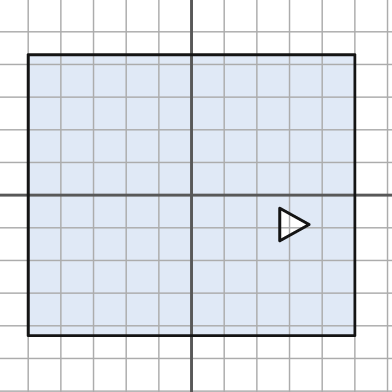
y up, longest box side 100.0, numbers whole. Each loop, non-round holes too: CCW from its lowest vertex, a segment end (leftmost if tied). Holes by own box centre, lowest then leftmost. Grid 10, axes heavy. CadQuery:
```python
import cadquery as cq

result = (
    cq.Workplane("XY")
    .moveTo(-50.0, -43.0)
    .lineTo(50.0, -43.0)
    .lineTo(50.0, 43.0)
    .lineTo(-50.0, 43.0)
    .close()
    .moveTo(27.0, -14.0)
    .lineTo(36.0, -9.0)
    .lineTo(27.0, -4.0)
    .close()
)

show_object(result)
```